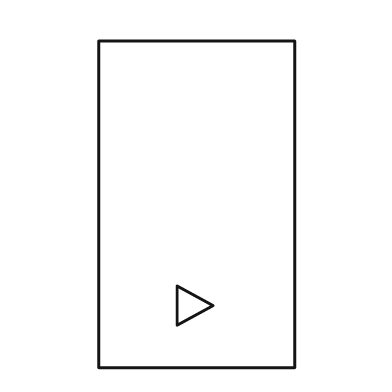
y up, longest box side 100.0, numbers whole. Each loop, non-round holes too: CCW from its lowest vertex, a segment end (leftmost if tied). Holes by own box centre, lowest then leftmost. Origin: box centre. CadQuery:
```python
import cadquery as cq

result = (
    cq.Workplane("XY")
    .moveTo(-30.0, -50.0)
    .lineTo(30.0, -50.0)
    .lineTo(30.0, 50.0)
    .lineTo(-30.0, 50.0)
    .close()
    .moveTo(-6.0, -37.0)
    .lineTo(5.0, -31.0)
    .lineTo(-6.0, -25.0)
    .close()
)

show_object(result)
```